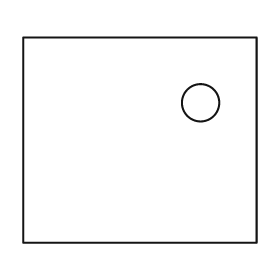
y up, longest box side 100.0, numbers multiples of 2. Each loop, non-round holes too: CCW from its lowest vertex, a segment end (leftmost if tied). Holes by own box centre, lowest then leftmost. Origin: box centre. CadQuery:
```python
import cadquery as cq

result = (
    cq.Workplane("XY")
    .moveTo(-50.0, -44.0)
    .lineTo(50.0, -44.0)
    .lineTo(50.0, 44.0)
    .lineTo(-50.0, 44.0)
    .close()
    .moveTo(26.0, 16.0)
    .circle(8.0)
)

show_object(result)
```